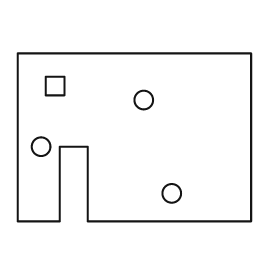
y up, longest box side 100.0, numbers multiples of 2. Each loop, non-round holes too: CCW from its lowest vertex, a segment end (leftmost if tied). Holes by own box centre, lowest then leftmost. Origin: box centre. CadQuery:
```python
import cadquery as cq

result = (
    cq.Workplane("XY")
    .moveTo(-50.0, -36.0)
    .lineTo(-32.0, -36.0)
    .lineTo(-32.0, -4.0)
    .lineTo(-20.0, -4.0)
    .lineTo(-20.0, -36.0)
    .lineTo(50.0, -36.0)
    .lineTo(50.0, 36.0)
    .lineTo(-50.0, 36.0)
    .close()
    .moveTo(16.0, -24.0)
    .circle(4.0)
    .moveTo(-40.0, -4.0)
    .circle(4.0)
    .moveTo(4.0, 16.0)
    .circle(4.0)
    .moveTo(-38.0, 18.0)
    .lineTo(-30.0, 18.0)
    .lineTo(-30.0, 26.0)
    .lineTo(-38.0, 26.0)
    .close()
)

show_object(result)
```